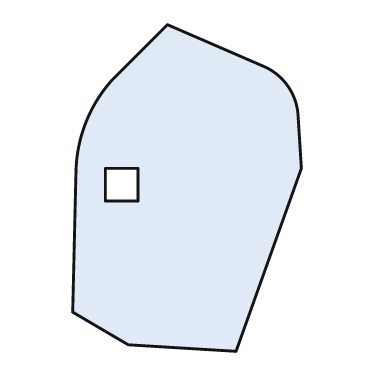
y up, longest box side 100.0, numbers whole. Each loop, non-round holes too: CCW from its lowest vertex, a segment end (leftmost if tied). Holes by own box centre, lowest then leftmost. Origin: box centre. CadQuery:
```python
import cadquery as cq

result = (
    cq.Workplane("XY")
    .moveTo(15.0, -50.0)
    .lineTo(35.0, 6.0)
    .lineTo(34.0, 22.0)
    .threePointArc((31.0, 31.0), (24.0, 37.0))
    .lineTo(-6.0, 50.0)
    .lineTo(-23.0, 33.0)
    .threePointArc((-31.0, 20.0), (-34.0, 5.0))
    .lineTo(-35.0, -38.0)
    .lineTo(-18.0, -48.0)
    .close()
    .moveTo(-25.0, -4.0)
    .lineTo(-15.0, -4.0)
    .lineTo(-15.0, 6.0)
    .lineTo(-25.0, 6.0)
    .close()
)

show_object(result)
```